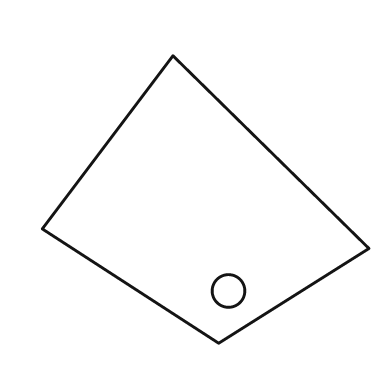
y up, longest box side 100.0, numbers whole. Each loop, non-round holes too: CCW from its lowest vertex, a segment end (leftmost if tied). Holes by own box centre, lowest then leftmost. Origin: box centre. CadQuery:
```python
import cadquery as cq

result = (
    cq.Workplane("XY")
    .moveTo(4.0, -44.0)
    .lineTo(50.0, -15.0)
    .lineTo(-10.0, 44.0)
    .lineTo(-50.0, -9.0)
    .close()
    .moveTo(7.0, -28.0)
    .circle(5.0)
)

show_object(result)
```